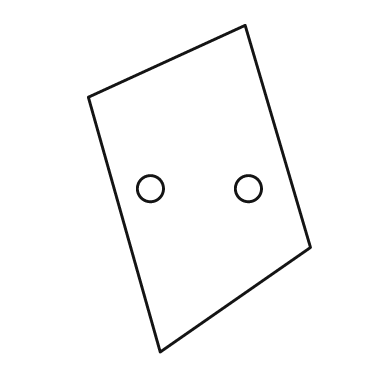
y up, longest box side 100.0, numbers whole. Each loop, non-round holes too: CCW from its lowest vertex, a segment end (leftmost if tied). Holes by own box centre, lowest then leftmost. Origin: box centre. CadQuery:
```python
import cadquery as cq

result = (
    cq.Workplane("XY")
    .moveTo(-12.0, -50.0)
    .lineTo(34.0, -18.0)
    .lineTo(14.0, 50.0)
    .lineTo(-34.0, 28.0)
    .close()
    .moveTo(-15.0, 0.0)
    .circle(4.0)
    .moveTo(15.0, 0.0)
    .circle(4.0)
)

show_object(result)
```